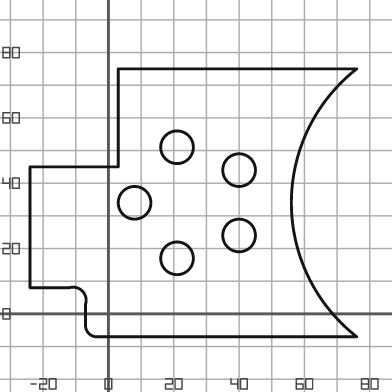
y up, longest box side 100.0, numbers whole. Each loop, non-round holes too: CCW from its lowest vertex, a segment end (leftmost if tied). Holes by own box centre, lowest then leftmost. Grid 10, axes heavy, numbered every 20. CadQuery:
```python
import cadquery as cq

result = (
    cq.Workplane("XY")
    .moveTo(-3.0, -7.0)
    .lineTo(76.0, -7.0)
    .threePointArc((56.0, 34.0), (76.0, 75.0))
    .lineTo(3.0, 75.0)
    .lineTo(3.0, 45.0)
    .lineTo(-24.0, 45.0)
    .lineTo(-24.0, 8.0)
    .lineTo(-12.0, 8.0)
    .threePointArc((-8.0, 7.0), (-7.0, 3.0))
    .lineTo(-7.0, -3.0)
    .threePointArc((-6.0, -6.0), (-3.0, -7.0))
    .close()
    .moveTo(21.0, 17.0)
    .circle(5.0)
    .moveTo(40.0, 24.0)
    .circle(5.0)
    .moveTo(8.0, 34.0)
    .circle(5.0)
    .moveTo(40.0, 44.0)
    .circle(5.0)
    .moveTo(21.0, 51.0)
    .circle(5.0)
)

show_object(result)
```